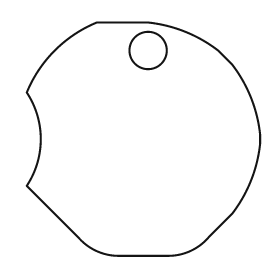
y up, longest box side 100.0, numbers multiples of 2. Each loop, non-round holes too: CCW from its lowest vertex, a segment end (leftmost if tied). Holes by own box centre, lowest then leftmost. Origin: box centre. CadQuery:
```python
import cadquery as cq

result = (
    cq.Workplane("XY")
    .moveTo(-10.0, -50.0)
    .lineTo(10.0, -50.0)
    .threePointArc((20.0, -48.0), (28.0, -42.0))
    .lineTo(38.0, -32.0)
    .threePointArc((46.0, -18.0), (50.0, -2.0))
    .lineTo(50.0, 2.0)
    .threePointArc((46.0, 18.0), (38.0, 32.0))
    .lineTo(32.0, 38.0)
    .threePointArc((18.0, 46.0), (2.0, 50.0))
    .lineTo(-20.0, 50.0)
    .threePointArc((-38.0, 38.0), (-50.0, 20.0))
    .threePointArc((-44.0, 0.0), (-50.0, -20.0))
    .lineTo(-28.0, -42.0)
    .threePointArc((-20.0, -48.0), (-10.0, -50.0))
    .close()
    .moveTo(2.0, 38.0)
    .circle(8.0)
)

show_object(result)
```